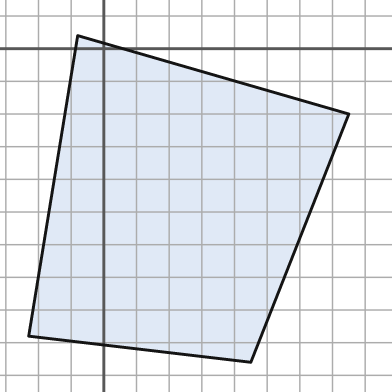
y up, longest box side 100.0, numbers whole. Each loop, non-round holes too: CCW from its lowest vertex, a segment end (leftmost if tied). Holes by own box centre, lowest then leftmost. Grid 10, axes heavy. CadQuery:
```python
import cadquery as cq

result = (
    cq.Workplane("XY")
    .moveTo(45.0, -96.0)
    .lineTo(75.0, -20.0)
    .lineTo(-8.0, 4.0)
    .lineTo(-23.0, -88.0)
    .close()
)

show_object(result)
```